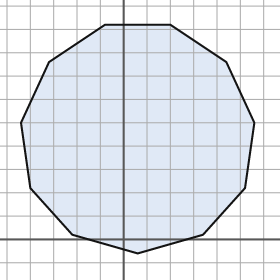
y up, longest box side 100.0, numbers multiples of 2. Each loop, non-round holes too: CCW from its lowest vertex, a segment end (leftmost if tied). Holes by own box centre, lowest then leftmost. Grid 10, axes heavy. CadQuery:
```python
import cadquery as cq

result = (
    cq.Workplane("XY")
    .moveTo(6.0, -6.0)
    .lineTo(34.0, 2.0)
    .lineTo(52.0, 22.0)
    .lineTo(56.0, 50.0)
    .lineTo(44.0, 76.0)
    .lineTo(20.0, 92.0)
    .lineTo(-8.0, 92.0)
    .lineTo(-32.0, 76.0)
    .lineTo(-44.0, 50.0)
    .lineTo(-40.0, 22.0)
    .lineTo(-22.0, 2.0)
    .close()
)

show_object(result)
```